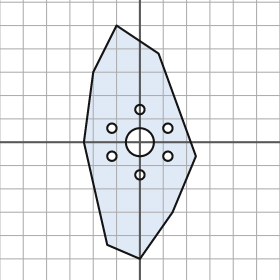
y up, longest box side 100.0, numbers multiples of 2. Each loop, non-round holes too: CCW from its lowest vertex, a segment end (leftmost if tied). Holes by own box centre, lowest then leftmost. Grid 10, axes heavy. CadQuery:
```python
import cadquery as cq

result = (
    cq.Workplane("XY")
    .moveTo(0.0, -50.0)
    .lineTo(14.0, -30.0)
    .lineTo(24.0, -6.0)
    .lineTo(8.0, 38.0)
    .lineTo(-10.0, 50.0)
    .lineTo(-20.0, 30.0)
    .lineTo(-24.0, 0.0)
    .lineTo(-14.0, -44.0)
    .close()
    .moveTo(0.0, -14.0)
    .circle(2.0)
    .moveTo(-12.0, -6.0)
    .circle(2.0)
    .moveTo(12.0, -6.0)
    .circle(2.0)
    .moveTo(0.0, 0.0)
    .circle(6.0)
    .moveTo(-12.0, 6.0)
    .circle(2.0)
    .moveTo(12.0, 6.0)
    .circle(2.0)
    .moveTo(0.0, 14.0)
    .circle(2.0)
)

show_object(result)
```